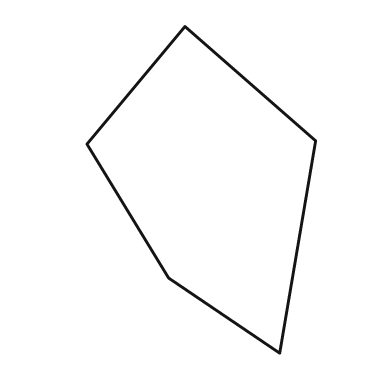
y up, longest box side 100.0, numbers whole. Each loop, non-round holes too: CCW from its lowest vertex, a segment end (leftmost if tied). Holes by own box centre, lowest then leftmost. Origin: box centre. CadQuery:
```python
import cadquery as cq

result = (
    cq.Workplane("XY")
    .moveTo(24.0, -50.0)
    .lineTo(35.0, 15.0)
    .lineTo(-5.0, 50.0)
    .lineTo(-35.0, 14.0)
    .lineTo(-10.0, -27.0)
    .close()
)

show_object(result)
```